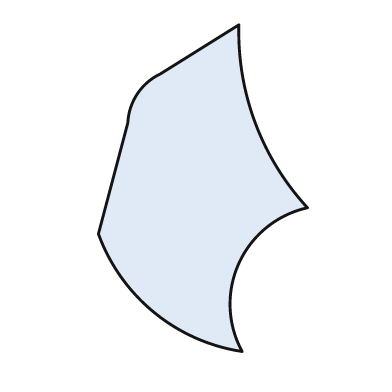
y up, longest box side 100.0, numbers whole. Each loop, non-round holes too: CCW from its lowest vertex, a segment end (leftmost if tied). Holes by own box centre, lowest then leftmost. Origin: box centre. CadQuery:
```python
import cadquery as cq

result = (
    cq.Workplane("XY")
    .moveTo(12.0, -50.0)
    .threePointArc((11.0, -23.0), (32.0, -6.0))
    .threePointArc((16.0, 20.0), (11.0, 50.0))
    .lineTo(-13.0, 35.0)
    .threePointArc((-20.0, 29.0), (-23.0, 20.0))
    .lineTo(-32.0, -14.0)
    .threePointArc((-15.0, -38.0), (12.0, -50.0))
    .close()
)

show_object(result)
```